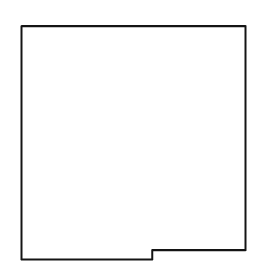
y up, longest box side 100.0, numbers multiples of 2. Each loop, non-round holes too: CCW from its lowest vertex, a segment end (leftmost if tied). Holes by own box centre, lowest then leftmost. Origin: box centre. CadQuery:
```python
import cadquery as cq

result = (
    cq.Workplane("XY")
    .moveTo(-48.0, -50.0)
    .lineTo(8.0, -50.0)
    .lineTo(8.0, -46.0)
    .lineTo(48.0, -46.0)
    .lineTo(48.0, 50.0)
    .lineTo(-48.0, 50.0)
    .close()
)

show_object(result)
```